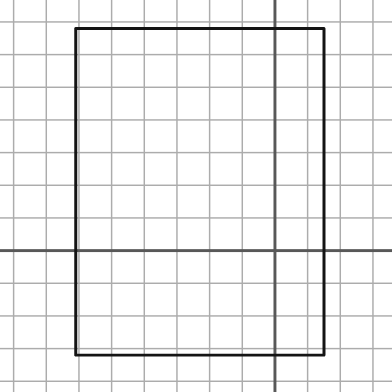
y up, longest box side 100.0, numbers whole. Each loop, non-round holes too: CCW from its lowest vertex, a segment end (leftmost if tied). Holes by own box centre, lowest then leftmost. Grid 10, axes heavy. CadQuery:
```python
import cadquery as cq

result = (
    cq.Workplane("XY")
    .moveTo(-61.0, -32.0)
    .lineTo(15.0, -32.0)
    .lineTo(15.0, 68.0)
    .lineTo(-61.0, 68.0)
    .close()
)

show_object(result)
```